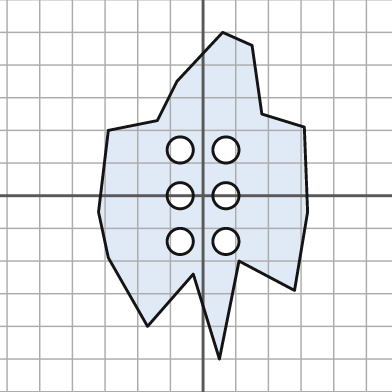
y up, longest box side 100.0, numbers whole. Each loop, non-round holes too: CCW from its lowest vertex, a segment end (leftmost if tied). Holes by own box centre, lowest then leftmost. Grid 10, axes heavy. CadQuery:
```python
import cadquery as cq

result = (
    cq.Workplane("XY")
    .moveTo(5.0, -50.0)
    .lineTo(11.0, -20.0)
    .lineTo(28.0, -29.0)
    .lineTo(32.0, -5.0)
    .lineTo(31.0, 21.0)
    .lineTo(18.0, 25.0)
    .lineTo(15.0, 46.0)
    .lineTo(6.0, 50.0)
    .lineTo(-8.0, 35.0)
    .lineTo(-14.0, 23.0)
    .lineTo(-29.0, 20.0)
    .lineTo(-32.0, -5.0)
    .lineTo(-29.0, -19.0)
    .lineTo(-17.0, -40.0)
    .lineTo(-3.0, -24.0)
    .close()
    .moveTo(-7.0, -14.0)
    .circle(4.0)
    .moveTo(7.0, -14.0)
    .circle(4.0)
    .moveTo(-7.0, 0.0)
    .circle(4.0)
    .moveTo(7.0, 0.0)
    .circle(4.0)
    .moveTo(-7.0, 14.0)
    .circle(4.0)
    .moveTo(7.0, 14.0)
    .circle(4.0)
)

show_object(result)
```